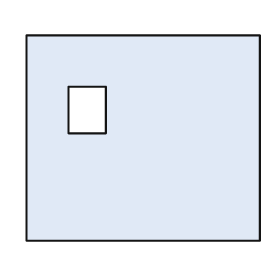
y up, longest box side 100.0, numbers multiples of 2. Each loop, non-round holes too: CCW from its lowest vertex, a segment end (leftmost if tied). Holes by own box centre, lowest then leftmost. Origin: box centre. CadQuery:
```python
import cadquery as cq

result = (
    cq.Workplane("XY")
    .moveTo(-50.0, -44.0)
    .lineTo(50.0, -44.0)
    .lineTo(50.0, 44.0)
    .lineTo(-50.0, 44.0)
    .close()
    .moveTo(-32.0, 2.0)
    .lineTo(-16.0, 2.0)
    .lineTo(-16.0, 22.0)
    .lineTo(-32.0, 22.0)
    .close()
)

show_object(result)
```